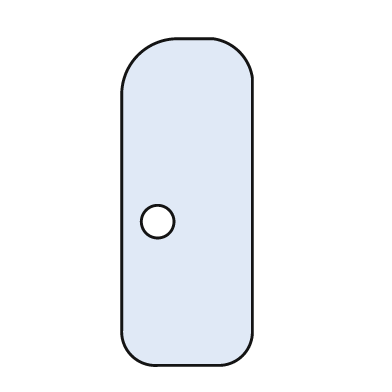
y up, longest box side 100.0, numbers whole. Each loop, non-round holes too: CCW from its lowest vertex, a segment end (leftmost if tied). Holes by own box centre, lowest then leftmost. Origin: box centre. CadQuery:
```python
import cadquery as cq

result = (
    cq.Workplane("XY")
    .moveTo(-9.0, -50.0)
    .lineTo(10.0, -50.0)
    .threePointArc((17.0, -47.0), (20.0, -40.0))
    .lineTo(20.0, 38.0)
    .threePointArc((16.0, 46.0), (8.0, 50.0))
    .lineTo(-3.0, 50.0)
    .threePointArc((-15.0, 45.0), (-20.0, 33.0))
    .lineTo(-20.0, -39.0)
    .threePointArc((-17.0, -47.0), (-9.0, -50.0))
    .close()
    .moveTo(-9.0, -6.0)
    .circle(5.0)
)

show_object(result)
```